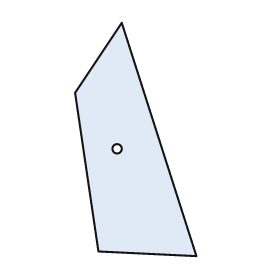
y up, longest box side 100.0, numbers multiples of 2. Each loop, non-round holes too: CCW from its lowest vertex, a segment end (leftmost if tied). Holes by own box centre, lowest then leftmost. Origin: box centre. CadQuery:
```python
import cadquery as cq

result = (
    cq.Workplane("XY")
    .moveTo(26.0, -50.0)
    .lineTo(-6.0, 50.0)
    .lineTo(-26.0, 20.0)
    .lineTo(-16.0, -48.0)
    .close()
    .moveTo(-8.0, -4.0)
    .circle(2.0)
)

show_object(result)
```